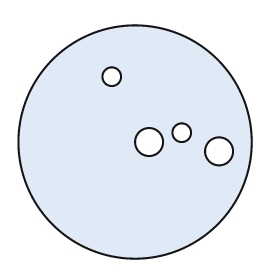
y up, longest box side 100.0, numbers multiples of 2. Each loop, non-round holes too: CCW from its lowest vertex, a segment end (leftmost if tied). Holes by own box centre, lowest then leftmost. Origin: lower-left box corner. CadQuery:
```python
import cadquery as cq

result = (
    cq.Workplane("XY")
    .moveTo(50.0, 50.0)
    .circle(50.0)
    .moveTo(86.0, 46.0)
    .circle(6.0)
    .moveTo(56.0, 50.0)
    .circle(6.0)
    .moveTo(70.0, 54.0)
    .circle(4.0)
    .moveTo(40.0, 78.0)
    .circle(4.0)
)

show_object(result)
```